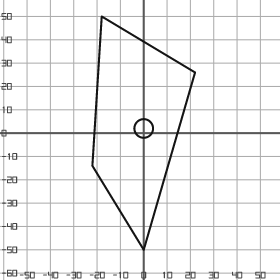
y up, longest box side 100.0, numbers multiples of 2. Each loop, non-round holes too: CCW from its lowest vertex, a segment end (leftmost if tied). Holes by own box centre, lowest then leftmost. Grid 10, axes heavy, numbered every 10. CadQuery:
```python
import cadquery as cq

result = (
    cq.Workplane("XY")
    .moveTo(0.0, -50.0)
    .lineTo(22.0, 26.0)
    .lineTo(-18.0, 50.0)
    .lineTo(-22.0, -14.0)
    .close()
    .moveTo(0.0, 2.0)
    .circle(4.0)
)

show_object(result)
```